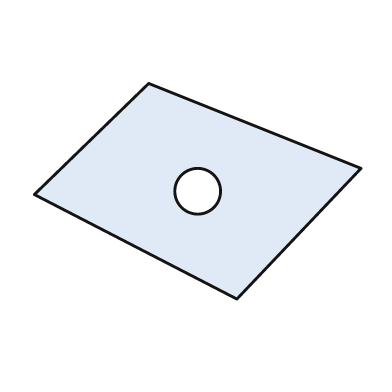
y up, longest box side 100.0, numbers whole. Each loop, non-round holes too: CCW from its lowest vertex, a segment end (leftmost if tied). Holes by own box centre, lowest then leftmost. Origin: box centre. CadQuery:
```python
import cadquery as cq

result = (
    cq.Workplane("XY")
    .moveTo(12.0, -33.0)
    .lineTo(50.0, 7.0)
    .lineTo(-15.0, 33.0)
    .lineTo(-50.0, -1.0)
    .close()
    .moveTo(0.0, 0.0)
    .circle(7.0)
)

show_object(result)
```